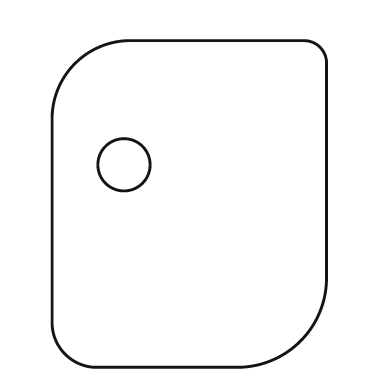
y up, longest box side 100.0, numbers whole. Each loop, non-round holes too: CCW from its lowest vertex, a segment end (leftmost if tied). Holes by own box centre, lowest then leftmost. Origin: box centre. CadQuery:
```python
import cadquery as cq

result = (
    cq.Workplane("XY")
    .moveTo(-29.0, -50.0)
    .lineTo(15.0, -50.0)
    .threePointArc((34.0, -42.0), (42.0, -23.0))
    .lineTo(42.0, 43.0)
    .threePointArc((40.0, 48.0), (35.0, 50.0))
    .lineTo(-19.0, 50.0)
    .threePointArc((-35.0, 43.0), (-42.0, 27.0))
    .lineTo(-42.0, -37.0)
    .threePointArc((-38.0, -46.0), (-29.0, -50.0))
    .close()
    .moveTo(-20.0, 12.0)
    .circle(8.0)
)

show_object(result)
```